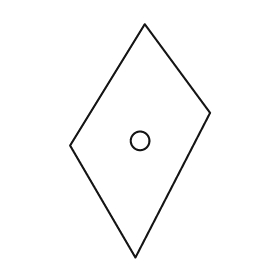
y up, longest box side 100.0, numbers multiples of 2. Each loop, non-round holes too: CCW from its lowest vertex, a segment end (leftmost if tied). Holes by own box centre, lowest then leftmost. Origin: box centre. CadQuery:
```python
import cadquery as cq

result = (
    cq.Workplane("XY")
    .moveTo(-2.0, -50.0)
    .lineTo(30.0, 12.0)
    .lineTo(2.0, 50.0)
    .lineTo(-30.0, -2.0)
    .close()
    .moveTo(0.0, 0.0)
    .circle(4.0)
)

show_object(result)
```